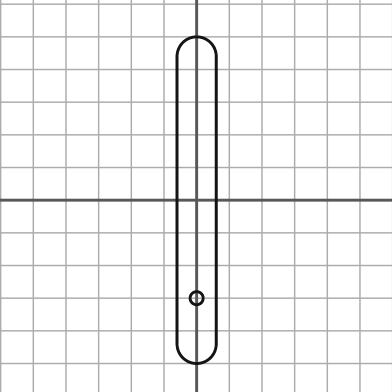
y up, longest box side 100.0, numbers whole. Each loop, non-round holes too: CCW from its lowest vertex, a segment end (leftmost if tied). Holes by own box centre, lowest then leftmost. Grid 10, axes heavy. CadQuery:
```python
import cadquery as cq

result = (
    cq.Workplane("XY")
    .moveTo(-6.0, -44.0)
    .threePointArc((0.0, -50.0), (6.0, -44.0))
    .lineTo(6.0, 44.0)
    .threePointArc((0.0, 50.0), (-6.0, 44.0))
    .close()
    .moveTo(0.0, -30.0)
    .circle(2.0)
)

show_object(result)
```